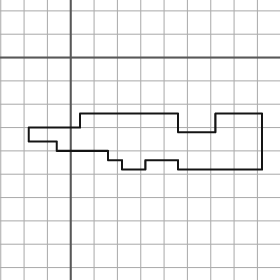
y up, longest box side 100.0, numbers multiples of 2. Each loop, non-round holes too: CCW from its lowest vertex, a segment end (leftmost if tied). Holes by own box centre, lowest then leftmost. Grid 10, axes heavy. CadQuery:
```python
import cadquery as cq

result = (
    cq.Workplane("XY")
    .moveTo(22.0, -48.0)
    .lineTo(32.0, -48.0)
    .lineTo(32.0, -44.0)
    .lineTo(46.0, -44.0)
    .lineTo(46.0, -48.0)
    .lineTo(82.0, -48.0)
    .lineTo(82.0, -24.0)
    .lineTo(62.0, -24.0)
    .lineTo(62.0, -32.0)
    .lineTo(46.0, -32.0)
    .lineTo(46.0, -24.0)
    .lineTo(4.0, -24.0)
    .lineTo(4.0, -30.0)
    .lineTo(-18.0, -30.0)
    .lineTo(-18.0, -36.0)
    .lineTo(-6.0, -36.0)
    .lineTo(-6.0, -40.0)
    .lineTo(16.0, -40.0)
    .lineTo(16.0, -44.0)
    .lineTo(22.0, -44.0)
    .close()
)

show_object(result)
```